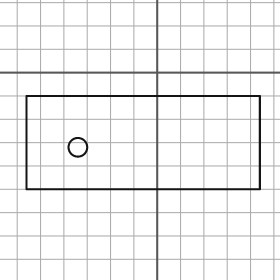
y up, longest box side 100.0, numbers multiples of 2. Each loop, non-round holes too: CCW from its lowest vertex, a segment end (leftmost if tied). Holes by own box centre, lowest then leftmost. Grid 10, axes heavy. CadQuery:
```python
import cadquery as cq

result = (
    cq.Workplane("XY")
    .moveTo(-56.0, -50.0)
    .lineTo(44.0, -50.0)
    .lineTo(44.0, -10.0)
    .lineTo(-56.0, -10.0)
    .close()
    .moveTo(-34.0, -32.0)
    .circle(4.0)
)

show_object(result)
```